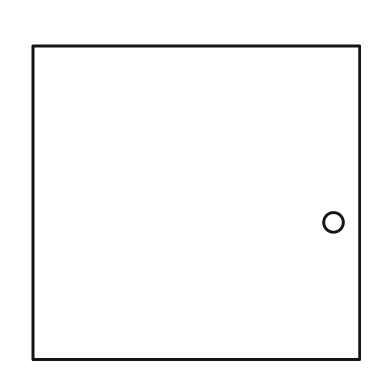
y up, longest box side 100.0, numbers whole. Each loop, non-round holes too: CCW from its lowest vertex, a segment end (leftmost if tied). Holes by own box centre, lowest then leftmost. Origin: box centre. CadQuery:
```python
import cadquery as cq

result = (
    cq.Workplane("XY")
    .moveTo(-50.0, -48.0)
    .lineTo(50.0, -48.0)
    .lineTo(50.0, 48.0)
    .lineTo(-50.0, 48.0)
    .close()
    .moveTo(42.0, -6.0)
    .circle(3.0)
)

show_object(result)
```